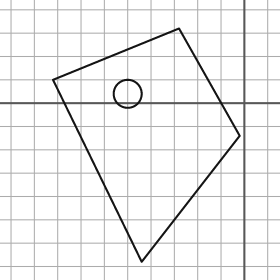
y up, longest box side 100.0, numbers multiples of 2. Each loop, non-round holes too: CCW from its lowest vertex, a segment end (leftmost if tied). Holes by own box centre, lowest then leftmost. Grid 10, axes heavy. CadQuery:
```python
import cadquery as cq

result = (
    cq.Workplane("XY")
    .moveTo(-44.0, -68.0)
    .lineTo(-2.0, -14.0)
    .lineTo(-28.0, 32.0)
    .lineTo(-82.0, 10.0)
    .close()
    .moveTo(-50.0, 4.0)
    .circle(6.0)
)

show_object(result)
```